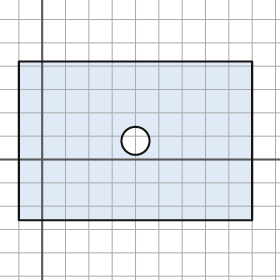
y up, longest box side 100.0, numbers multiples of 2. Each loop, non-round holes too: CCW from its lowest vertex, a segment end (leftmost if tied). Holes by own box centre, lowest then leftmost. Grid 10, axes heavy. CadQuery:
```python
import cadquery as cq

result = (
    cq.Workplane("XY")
    .moveTo(-10.0, -26.0)
    .lineTo(90.0, -26.0)
    .lineTo(90.0, 42.0)
    .lineTo(-10.0, 42.0)
    .close()
    .moveTo(40.0, 8.0)
    .circle(6.0)
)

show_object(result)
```